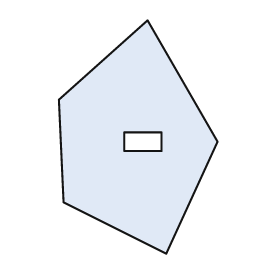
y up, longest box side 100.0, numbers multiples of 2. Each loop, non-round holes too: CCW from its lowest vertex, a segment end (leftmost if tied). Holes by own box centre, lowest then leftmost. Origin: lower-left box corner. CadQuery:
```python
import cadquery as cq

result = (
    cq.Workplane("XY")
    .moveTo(46.0, 0.0)
    .lineTo(68.0, 48.0)
    .lineTo(38.0, 100.0)
    .lineTo(0.0, 66.0)
    .lineTo(2.0, 22.0)
    .close()
    .moveTo(28.0, 44.0)
    .lineTo(44.0, 44.0)
    .lineTo(44.0, 52.0)
    .lineTo(28.0, 52.0)
    .close()
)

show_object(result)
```